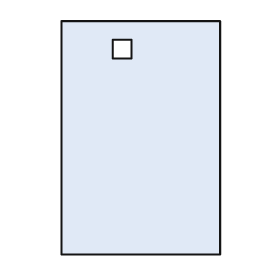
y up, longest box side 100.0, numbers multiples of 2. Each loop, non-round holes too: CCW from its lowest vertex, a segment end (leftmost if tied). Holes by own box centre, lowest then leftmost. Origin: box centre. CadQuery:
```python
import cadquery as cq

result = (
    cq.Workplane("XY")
    .moveTo(-34.0, -50.0)
    .lineTo(34.0, -50.0)
    .lineTo(34.0, 50.0)
    .lineTo(-34.0, 50.0)
    .close()
    .moveTo(-12.0, 34.0)
    .lineTo(-4.0, 34.0)
    .lineTo(-4.0, 42.0)
    .lineTo(-12.0, 42.0)
    .close()
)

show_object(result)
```